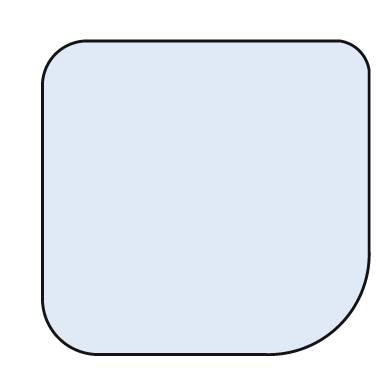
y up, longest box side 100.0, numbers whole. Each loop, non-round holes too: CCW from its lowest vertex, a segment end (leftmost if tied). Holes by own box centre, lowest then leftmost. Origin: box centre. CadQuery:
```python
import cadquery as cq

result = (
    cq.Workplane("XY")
    .moveTo(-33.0, -48.0)
    .lineTo(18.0, -48.0)
    .threePointArc((41.0, -39.0), (50.0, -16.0))
    .lineTo(50.0, 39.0)
    .threePointArc((47.0, 45.0), (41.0, 48.0))
    .lineTo(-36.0, 48.0)
    .threePointArc((-46.0, 44.0), (-50.0, 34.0))
    .lineTo(-50.0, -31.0)
    .threePointArc((-45.0, -43.0), (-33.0, -48.0))
    .close()
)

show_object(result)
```